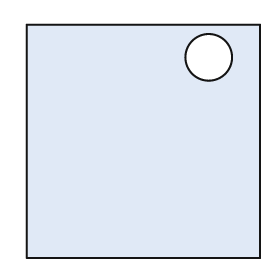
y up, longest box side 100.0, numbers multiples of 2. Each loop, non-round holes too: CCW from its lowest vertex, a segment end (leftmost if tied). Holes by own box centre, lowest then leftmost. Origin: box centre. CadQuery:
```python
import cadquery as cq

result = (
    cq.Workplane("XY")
    .moveTo(-50.0, -50.0)
    .lineTo(50.0, -50.0)
    .lineTo(50.0, 50.0)
    .lineTo(-50.0, 50.0)
    .close()
    .moveTo(28.0, 36.0)
    .circle(10.0)
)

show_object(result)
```